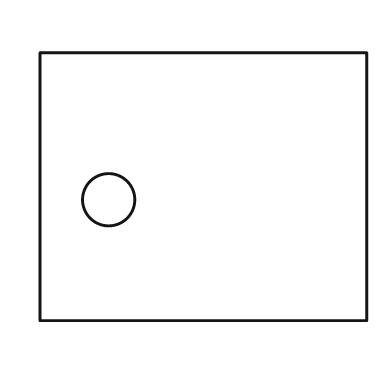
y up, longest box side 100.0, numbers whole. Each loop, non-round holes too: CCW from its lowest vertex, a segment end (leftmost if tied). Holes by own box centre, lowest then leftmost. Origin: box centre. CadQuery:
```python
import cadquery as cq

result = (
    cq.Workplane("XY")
    .moveTo(-50.0, -41.0)
    .lineTo(50.0, -41.0)
    .lineTo(50.0, 41.0)
    .lineTo(-50.0, 41.0)
    .close()
    .moveTo(-29.0, -4.0)
    .circle(8.0)
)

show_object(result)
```